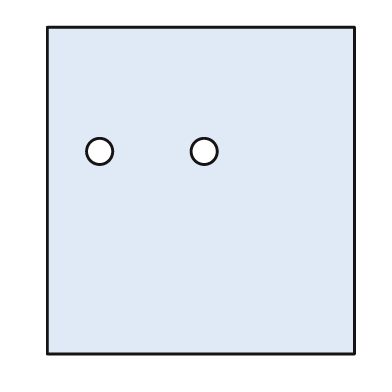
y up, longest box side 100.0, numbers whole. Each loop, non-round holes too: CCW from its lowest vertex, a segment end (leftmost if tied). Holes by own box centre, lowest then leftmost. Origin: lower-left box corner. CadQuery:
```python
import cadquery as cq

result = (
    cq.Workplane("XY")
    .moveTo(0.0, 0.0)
    .lineTo(94.0, 0.0)
    .lineTo(94.0, 100.0)
    .lineTo(0.0, 100.0)
    .close()
    .moveTo(16.0, 62.0)
    .circle(4.0)
    .moveTo(48.0, 62.0)
    .circle(4.0)
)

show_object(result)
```